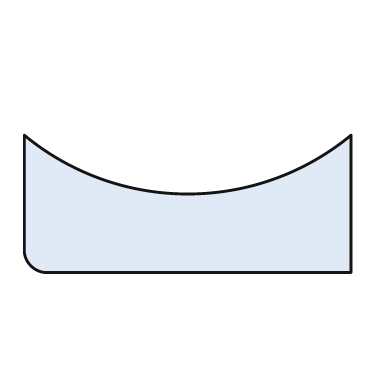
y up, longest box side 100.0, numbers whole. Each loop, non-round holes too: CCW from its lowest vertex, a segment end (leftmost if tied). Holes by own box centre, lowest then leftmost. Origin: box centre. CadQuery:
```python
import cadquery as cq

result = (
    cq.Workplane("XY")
    .moveTo(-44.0, -21.0)
    .lineTo(50.0, -21.0)
    .lineTo(50.0, 21.0)
    .threePointArc((0.0, 3.0), (-50.0, 21.0))
    .lineTo(-50.0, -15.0)
    .threePointArc((-48.0, -19.0), (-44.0, -21.0))
    .close()
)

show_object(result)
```